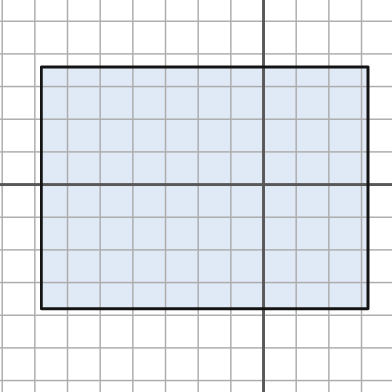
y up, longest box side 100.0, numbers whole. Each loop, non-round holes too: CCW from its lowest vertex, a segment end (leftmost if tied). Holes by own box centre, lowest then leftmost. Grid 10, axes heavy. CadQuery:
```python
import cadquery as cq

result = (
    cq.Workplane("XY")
    .moveTo(-68.0, -38.0)
    .lineTo(32.0, -38.0)
    .lineTo(32.0, 36.0)
    .lineTo(-68.0, 36.0)
    .close()
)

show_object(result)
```